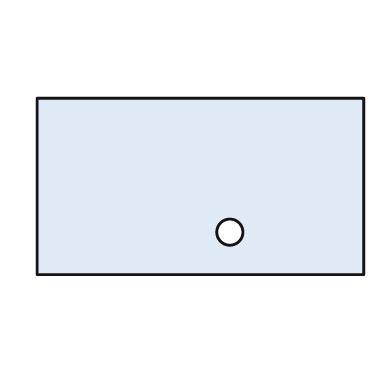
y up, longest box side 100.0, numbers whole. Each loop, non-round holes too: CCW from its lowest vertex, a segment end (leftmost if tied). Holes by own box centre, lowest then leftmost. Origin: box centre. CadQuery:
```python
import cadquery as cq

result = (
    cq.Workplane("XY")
    .moveTo(-50.0, -27.0)
    .lineTo(50.0, -27.0)
    .lineTo(50.0, 27.0)
    .lineTo(-50.0, 27.0)
    .close()
    .moveTo(9.0, -14.0)
    .circle(4.0)
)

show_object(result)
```